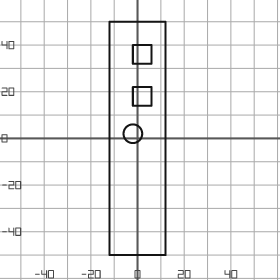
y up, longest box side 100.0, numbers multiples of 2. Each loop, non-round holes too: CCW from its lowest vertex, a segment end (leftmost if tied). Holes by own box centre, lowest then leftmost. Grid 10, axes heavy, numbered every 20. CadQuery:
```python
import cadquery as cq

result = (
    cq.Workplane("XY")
    .moveTo(-12.0, -50.0)
    .lineTo(12.0, -50.0)
    .lineTo(12.0, 50.0)
    .lineTo(-12.0, 50.0)
    .close()
    .moveTo(-2.0, 2.0)
    .circle(4.0)
    .moveTo(-2.0, 14.0)
    .lineTo(6.0, 14.0)
    .lineTo(6.0, 22.0)
    .lineTo(-2.0, 22.0)
    .close()
    .moveTo(-2.0, 32.0)
    .lineTo(6.0, 32.0)
    .lineTo(6.0, 40.0)
    .lineTo(-2.0, 40.0)
    .close()
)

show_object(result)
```